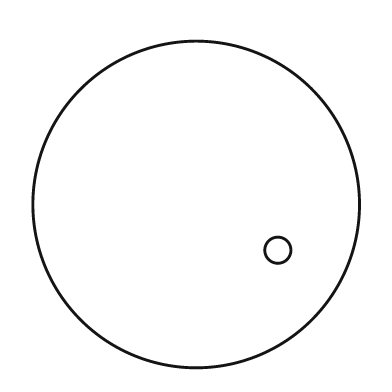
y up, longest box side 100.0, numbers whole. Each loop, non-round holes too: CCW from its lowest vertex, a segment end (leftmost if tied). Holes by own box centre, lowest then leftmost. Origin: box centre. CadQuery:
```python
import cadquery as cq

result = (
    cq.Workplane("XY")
    .moveTo(0.0, 0.0)
    .circle(50.0)
    .moveTo(25.0, -14.0)
    .circle(4.0)
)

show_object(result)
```